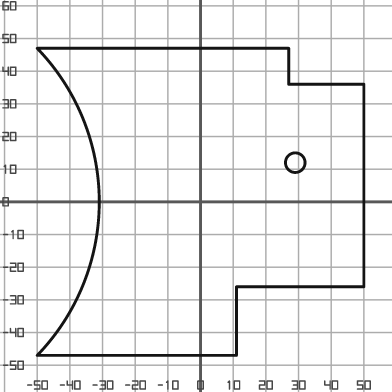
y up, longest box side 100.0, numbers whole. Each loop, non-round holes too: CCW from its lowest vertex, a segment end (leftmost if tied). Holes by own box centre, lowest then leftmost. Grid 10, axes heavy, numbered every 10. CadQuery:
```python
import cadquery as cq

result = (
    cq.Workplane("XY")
    .moveTo(-50.0, -47.0)
    .lineTo(11.0, -47.0)
    .lineTo(11.0, -26.0)
    .lineTo(50.0, -26.0)
    .lineTo(50.0, 36.0)
    .lineTo(27.0, 36.0)
    .lineTo(27.0, 47.0)
    .lineTo(-50.0, 47.0)
    .threePointArc((-31.0, 0.0), (-50.0, -47.0))
    .close()
    .moveTo(29.0, 12.0)
    .circle(3.0)
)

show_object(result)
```